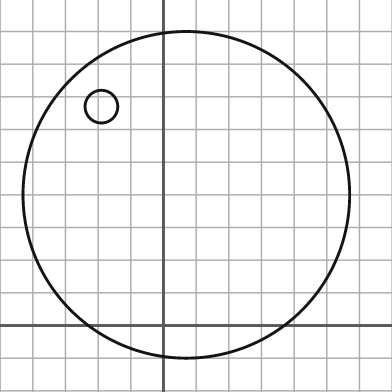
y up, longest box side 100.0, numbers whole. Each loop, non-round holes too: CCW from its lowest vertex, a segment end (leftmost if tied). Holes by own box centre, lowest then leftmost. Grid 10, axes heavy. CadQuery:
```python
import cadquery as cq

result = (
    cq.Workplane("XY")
    .moveTo(7.0, 40.0)
    .circle(50.0)
    .moveTo(-19.0, 67.0)
    .circle(5.0)
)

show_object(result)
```